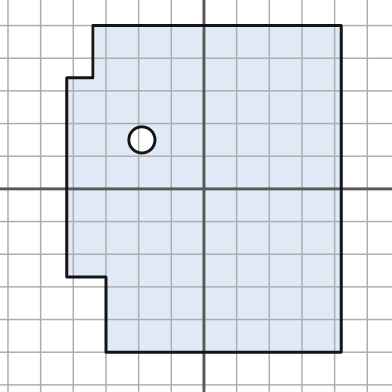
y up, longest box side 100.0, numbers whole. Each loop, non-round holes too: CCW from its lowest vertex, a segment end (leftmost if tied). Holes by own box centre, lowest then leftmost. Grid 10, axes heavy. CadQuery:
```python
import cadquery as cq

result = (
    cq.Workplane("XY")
    .moveTo(-30.0, -50.0)
    .lineTo(42.0, -50.0)
    .lineTo(42.0, 50.0)
    .lineTo(-34.0, 50.0)
    .lineTo(-34.0, 34.0)
    .lineTo(-42.0, 34.0)
    .lineTo(-42.0, -27.0)
    .lineTo(-30.0, -27.0)
    .close()
    .moveTo(-19.0, 15.0)
    .circle(4.0)
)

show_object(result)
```